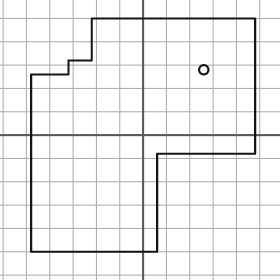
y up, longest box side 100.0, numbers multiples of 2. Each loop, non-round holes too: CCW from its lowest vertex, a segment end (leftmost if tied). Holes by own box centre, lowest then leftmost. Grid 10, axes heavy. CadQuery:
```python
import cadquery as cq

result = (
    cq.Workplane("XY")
    .moveTo(-48.0, -50.0)
    .lineTo(6.0, -50.0)
    .lineTo(6.0, -8.0)
    .lineTo(48.0, -8.0)
    .lineTo(48.0, 50.0)
    .lineTo(-22.0, 50.0)
    .lineTo(-22.0, 32.0)
    .lineTo(-32.0, 32.0)
    .lineTo(-32.0, 26.0)
    .lineTo(-48.0, 26.0)
    .close()
    .moveTo(26.0, 28.0)
    .circle(2.0)
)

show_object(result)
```